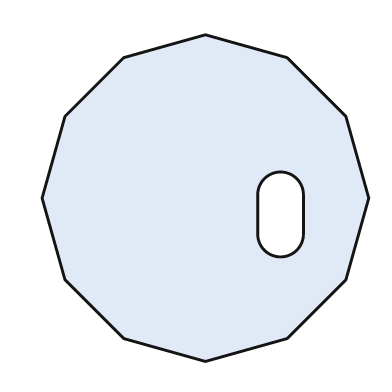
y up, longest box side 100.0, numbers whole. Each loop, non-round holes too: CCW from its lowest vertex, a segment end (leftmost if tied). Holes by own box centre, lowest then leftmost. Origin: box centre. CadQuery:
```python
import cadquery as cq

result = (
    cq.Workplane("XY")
    .moveTo(0.0, -50.0)
    .lineTo(25.0, -43.0)
    .lineTo(43.0, -25.0)
    .lineTo(50.0, 0.0)
    .lineTo(43.0, 25.0)
    .lineTo(25.0, 43.0)
    .lineTo(0.0, 50.0)
    .lineTo(-25.0, 43.0)
    .lineTo(-43.0, 25.0)
    .lineTo(-50.0, 0.0)
    .lineTo(-43.0, -25.0)
    .lineTo(-25.0, -43.0)
    .close()
    .moveTo(16.0, -11.0)
    .threePointArc((23.0, -18.0), (30.0, -11.0))
    .lineTo(30.0, 1.0)
    .threePointArc((23.0, 8.0), (16.0, 1.0))
    .close()
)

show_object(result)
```